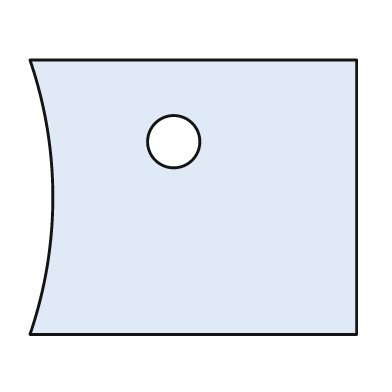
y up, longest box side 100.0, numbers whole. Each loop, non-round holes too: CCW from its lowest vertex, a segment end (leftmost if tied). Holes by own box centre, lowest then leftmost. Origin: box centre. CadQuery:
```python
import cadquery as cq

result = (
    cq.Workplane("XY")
    .moveTo(-50.0, -42.0)
    .lineTo(50.0, -42.0)
    .lineTo(50.0, 42.0)
    .lineTo(-50.0, 42.0)
    .threePointArc((-43.0, 0.0), (-50.0, -42.0))
    .close()
    .moveTo(-6.0, 17.0)
    .circle(8.0)
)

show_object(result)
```